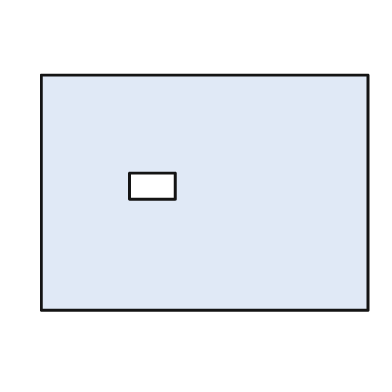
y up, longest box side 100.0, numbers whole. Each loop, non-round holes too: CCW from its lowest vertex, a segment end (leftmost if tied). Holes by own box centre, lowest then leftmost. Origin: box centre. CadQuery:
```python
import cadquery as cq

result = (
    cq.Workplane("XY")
    .moveTo(-50.0, -36.0)
    .lineTo(50.0, -36.0)
    .lineTo(50.0, 36.0)
    .lineTo(-50.0, 36.0)
    .close()
    .moveTo(-23.0, -2.0)
    .lineTo(-9.0, -2.0)
    .lineTo(-9.0, 6.0)
    .lineTo(-23.0, 6.0)
    .close()
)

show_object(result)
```